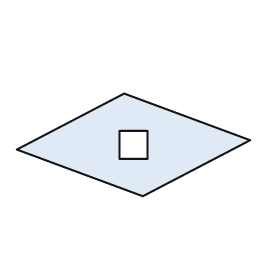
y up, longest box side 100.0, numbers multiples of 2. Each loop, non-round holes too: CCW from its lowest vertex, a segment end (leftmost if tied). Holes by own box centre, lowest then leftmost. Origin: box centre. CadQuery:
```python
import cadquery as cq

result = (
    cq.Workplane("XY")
    .moveTo(4.0, -22.0)
    .lineTo(50.0, 2.0)
    .lineTo(-4.0, 22.0)
    .lineTo(-50.0, -2.0)
    .close()
    .moveTo(-6.0, -6.0)
    .lineTo(6.0, -6.0)
    .lineTo(6.0, 6.0)
    .lineTo(-6.0, 6.0)
    .close()
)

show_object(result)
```